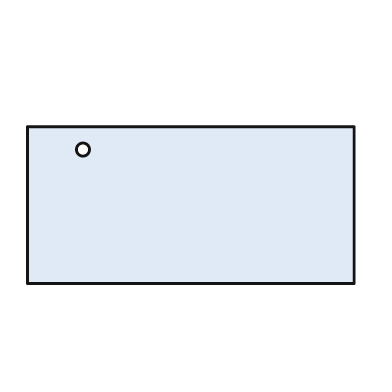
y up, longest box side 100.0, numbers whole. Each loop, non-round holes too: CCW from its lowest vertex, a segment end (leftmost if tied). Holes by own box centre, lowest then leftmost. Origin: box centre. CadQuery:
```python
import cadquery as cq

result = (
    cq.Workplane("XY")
    .moveTo(-50.0, -24.0)
    .lineTo(50.0, -24.0)
    .lineTo(50.0, 24.0)
    .lineTo(-50.0, 24.0)
    .close()
    .moveTo(-33.0, 17.0)
    .circle(2.0)
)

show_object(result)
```